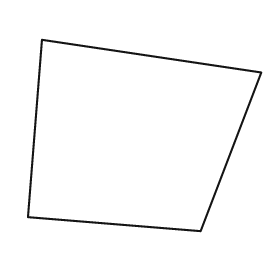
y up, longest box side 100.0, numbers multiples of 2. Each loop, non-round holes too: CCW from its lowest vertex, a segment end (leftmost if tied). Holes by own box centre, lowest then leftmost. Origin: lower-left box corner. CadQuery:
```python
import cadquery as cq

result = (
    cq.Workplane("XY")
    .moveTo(74.0, 0.0)
    .lineTo(100.0, 68.0)
    .lineTo(6.0, 82.0)
    .lineTo(0.0, 6.0)
    .close()
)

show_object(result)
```